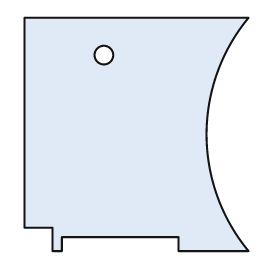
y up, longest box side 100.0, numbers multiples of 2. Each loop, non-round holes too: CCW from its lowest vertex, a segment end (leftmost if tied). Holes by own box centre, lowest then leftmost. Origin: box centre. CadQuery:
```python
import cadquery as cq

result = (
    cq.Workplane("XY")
    .moveTo(-36.0, -50.0)
    .lineTo(-32.0, -50.0)
    .lineTo(-32.0, -44.0)
    .lineTo(18.0, -44.0)
    .lineTo(18.0, -50.0)
    .lineTo(48.0, -50.0)
    .threePointArc((30.0, 0.0), (48.0, 50.0))
    .lineTo(-48.0, 50.0)
    .lineTo(-48.0, -40.0)
    .lineTo(-36.0, -40.0)
    .close()
    .moveTo(-14.0, 34.0)
    .circle(4.0)
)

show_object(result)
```